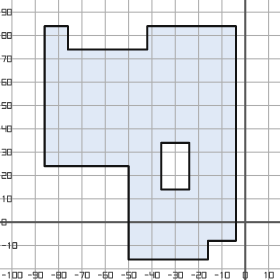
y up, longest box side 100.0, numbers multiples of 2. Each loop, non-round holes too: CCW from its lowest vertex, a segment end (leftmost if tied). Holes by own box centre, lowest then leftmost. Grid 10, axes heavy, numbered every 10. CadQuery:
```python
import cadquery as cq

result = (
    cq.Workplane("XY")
    .moveTo(-50.0, -16.0)
    .lineTo(-16.0, -16.0)
    .lineTo(-16.0, -8.0)
    .lineTo(-4.0, -8.0)
    .lineTo(-4.0, 84.0)
    .lineTo(-42.0, 84.0)
    .lineTo(-42.0, 74.0)
    .lineTo(-76.0, 74.0)
    .lineTo(-76.0, 84.0)
    .lineTo(-86.0, 84.0)
    .lineTo(-86.0, 24.0)
    .lineTo(-50.0, 24.0)
    .close()
    .moveTo(-36.0, 14.0)
    .lineTo(-24.0, 14.0)
    .lineTo(-24.0, 34.0)
    .lineTo(-36.0, 34.0)
    .close()
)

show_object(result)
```